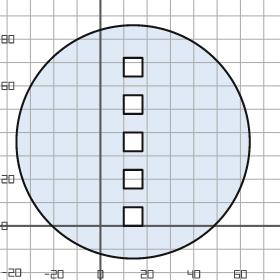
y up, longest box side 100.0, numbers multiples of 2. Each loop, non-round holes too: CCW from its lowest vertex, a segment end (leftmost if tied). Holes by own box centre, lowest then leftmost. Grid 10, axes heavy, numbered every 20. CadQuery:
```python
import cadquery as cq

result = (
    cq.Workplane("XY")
    .moveTo(14.0, 36.0)
    .circle(50.0)
    .moveTo(10.0, 0.0)
    .lineTo(18.0, 0.0)
    .lineTo(18.0, 8.0)
    .lineTo(10.0, 8.0)
    .close()
    .moveTo(10.0, 16.0)
    .lineTo(18.0, 16.0)
    .lineTo(18.0, 24.0)
    .lineTo(10.0, 24.0)
    .close()
    .moveTo(10.0, 32.0)
    .lineTo(18.0, 32.0)
    .lineTo(18.0, 40.0)
    .lineTo(10.0, 40.0)
    .close()
    .moveTo(10.0, 48.0)
    .lineTo(18.0, 48.0)
    .lineTo(18.0, 56.0)
    .lineTo(10.0, 56.0)
    .close()
    .moveTo(10.0, 64.0)
    .lineTo(18.0, 64.0)
    .lineTo(18.0, 72.0)
    .lineTo(10.0, 72.0)
    .close()
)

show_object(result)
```